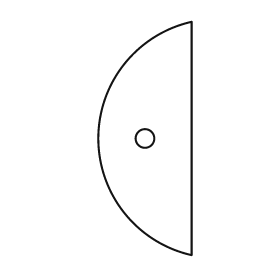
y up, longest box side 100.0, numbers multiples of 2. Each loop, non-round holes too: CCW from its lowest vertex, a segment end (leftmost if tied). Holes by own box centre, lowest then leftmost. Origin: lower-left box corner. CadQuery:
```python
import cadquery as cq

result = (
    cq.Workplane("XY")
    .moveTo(40.0, 0.0)
    .lineTo(40.0, 100.0)
    .threePointArc((0.0, 50.0), (40.0, 0.0))
    .close()
    .moveTo(20.0, 50.0)
    .circle(4.0)
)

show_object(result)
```